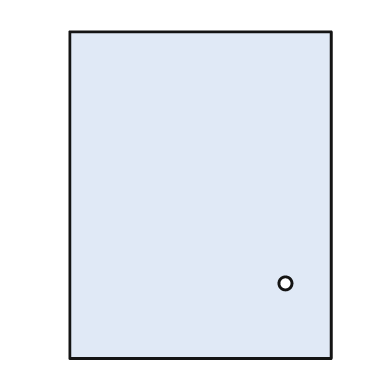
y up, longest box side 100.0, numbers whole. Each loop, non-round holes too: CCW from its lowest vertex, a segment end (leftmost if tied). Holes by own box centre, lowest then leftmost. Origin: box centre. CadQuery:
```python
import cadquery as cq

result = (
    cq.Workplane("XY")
    .moveTo(-40.0, -50.0)
    .lineTo(40.0, -50.0)
    .lineTo(40.0, 50.0)
    .lineTo(-40.0, 50.0)
    .close()
    .moveTo(26.0, -27.0)
    .circle(2.0)
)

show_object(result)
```